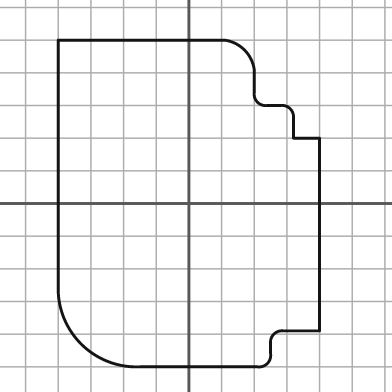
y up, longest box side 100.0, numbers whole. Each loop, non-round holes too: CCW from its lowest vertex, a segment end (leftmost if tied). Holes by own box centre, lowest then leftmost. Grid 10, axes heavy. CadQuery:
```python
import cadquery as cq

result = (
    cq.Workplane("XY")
    .moveTo(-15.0, -50.0)
    .lineTo(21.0, -50.0)
    .threePointArc((24.0, -49.0), (25.0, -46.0))
    .lineTo(25.0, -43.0)
    .threePointArc((26.0, -40.0), (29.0, -39.0))
    .lineTo(40.0, -39.0)
    .lineTo(40.0, 20.0)
    .lineTo(32.0, 20.0)
    .lineTo(32.0, 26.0)
    .threePointArc((31.0, 29.0), (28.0, 30.0))
    .lineTo(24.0, 30.0)
    .threePointArc((21.0, 31.0), (20.0, 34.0))
    .lineTo(20.0, 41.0)
    .threePointArc((17.0, 47.0), (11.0, 50.0))
    .lineTo(-40.0, 50.0)
    .lineTo(-40.0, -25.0)
    .threePointArc((-33.0, -43.0), (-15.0, -50.0))
    .close()
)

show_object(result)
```